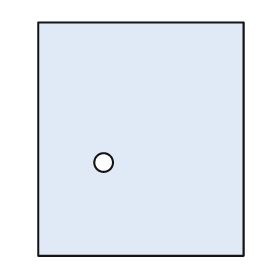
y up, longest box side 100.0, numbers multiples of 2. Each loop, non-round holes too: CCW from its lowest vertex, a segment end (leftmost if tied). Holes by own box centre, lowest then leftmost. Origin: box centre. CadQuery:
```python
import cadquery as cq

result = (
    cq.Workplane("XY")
    .moveTo(-44.0, -50.0)
    .lineTo(44.0, -50.0)
    .lineTo(44.0, 50.0)
    .lineTo(-44.0, 50.0)
    .close()
    .moveTo(-16.0, -10.0)
    .circle(4.0)
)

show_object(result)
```